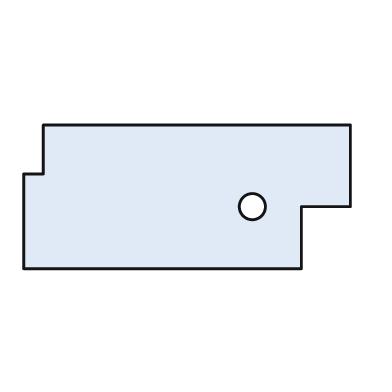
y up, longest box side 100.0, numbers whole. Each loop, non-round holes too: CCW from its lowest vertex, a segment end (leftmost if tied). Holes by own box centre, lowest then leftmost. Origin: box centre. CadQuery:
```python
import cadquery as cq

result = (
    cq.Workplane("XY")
    .moveTo(-50.0, -22.0)
    .lineTo(35.0, -22.0)
    .lineTo(35.0, -3.0)
    .lineTo(50.0, -3.0)
    .lineTo(50.0, 22.0)
    .lineTo(-44.0, 22.0)
    .lineTo(-44.0, 7.0)
    .lineTo(-50.0, 7.0)
    .close()
    .moveTo(20.0, -3.0)
    .circle(4.0)
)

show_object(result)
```